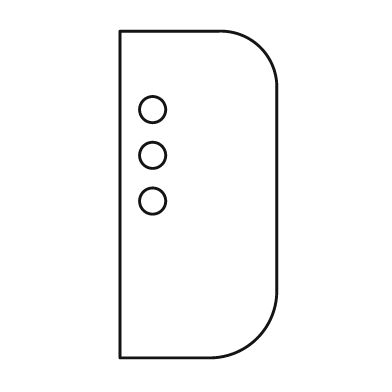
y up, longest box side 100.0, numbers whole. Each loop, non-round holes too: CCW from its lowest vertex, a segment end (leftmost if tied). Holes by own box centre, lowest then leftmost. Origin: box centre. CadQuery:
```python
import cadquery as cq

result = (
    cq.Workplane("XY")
    .moveTo(-24.0, -50.0)
    .lineTo(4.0, -50.0)
    .threePointArc((18.0, -44.0), (24.0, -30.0))
    .lineTo(24.0, 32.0)
    .threePointArc((19.0, 45.0), (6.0, 50.0))
    .lineTo(-24.0, 50.0)
    .close()
    .moveTo(-14.0, -2.0)
    .circle(4.0)
    .moveTo(-14.0, 12.0)
    .circle(4.0)
    .moveTo(-14.0, 26.0)
    .circle(4.0)
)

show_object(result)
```